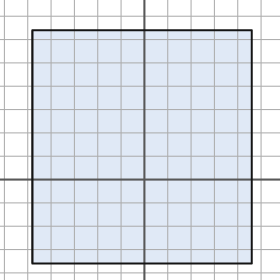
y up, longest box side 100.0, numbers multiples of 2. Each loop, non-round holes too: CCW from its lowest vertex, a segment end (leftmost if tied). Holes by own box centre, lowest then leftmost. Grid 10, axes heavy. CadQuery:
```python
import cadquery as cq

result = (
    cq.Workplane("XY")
    .moveTo(-48.0, -36.0)
    .lineTo(46.0, -36.0)
    .lineTo(46.0, 64.0)
    .lineTo(-48.0, 64.0)
    .close()
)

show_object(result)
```